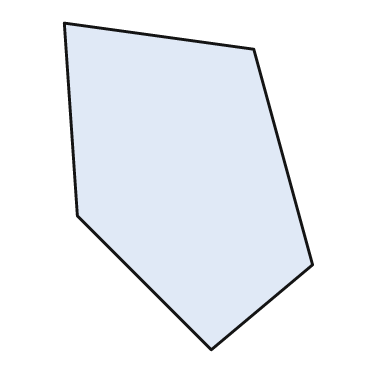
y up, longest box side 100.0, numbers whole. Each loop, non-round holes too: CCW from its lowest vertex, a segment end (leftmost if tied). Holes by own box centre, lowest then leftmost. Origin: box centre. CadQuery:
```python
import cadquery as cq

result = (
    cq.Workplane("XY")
    .moveTo(7.0, -50.0)
    .lineTo(38.0, -24.0)
    .lineTo(20.0, 42.0)
    .lineTo(-38.0, 50.0)
    .lineTo(-34.0, -9.0)
    .close()
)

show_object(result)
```